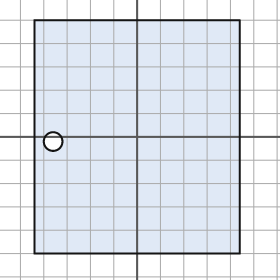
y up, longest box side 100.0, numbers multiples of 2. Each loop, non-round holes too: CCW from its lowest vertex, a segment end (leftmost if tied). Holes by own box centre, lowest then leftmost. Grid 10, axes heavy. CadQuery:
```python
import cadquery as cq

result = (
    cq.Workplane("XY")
    .moveTo(-44.0, -50.0)
    .lineTo(44.0, -50.0)
    .lineTo(44.0, 50.0)
    .lineTo(-44.0, 50.0)
    .close()
    .moveTo(-36.0, -2.0)
    .circle(4.0)
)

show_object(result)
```